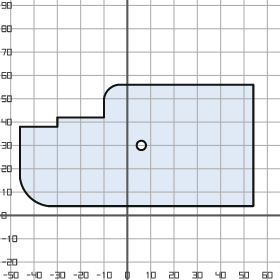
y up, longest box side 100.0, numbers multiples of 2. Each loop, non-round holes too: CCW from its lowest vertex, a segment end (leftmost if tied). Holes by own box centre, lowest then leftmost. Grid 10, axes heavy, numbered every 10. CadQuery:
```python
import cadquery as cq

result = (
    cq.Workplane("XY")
    .moveTo(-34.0, 4.0)
    .lineTo(54.0, 4.0)
    .lineTo(54.0, 56.0)
    .lineTo(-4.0, 56.0)
    .threePointArc((-8.0, 54.0), (-10.0, 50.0))
    .lineTo(-10.0, 42.0)
    .lineTo(-30.0, 42.0)
    .lineTo(-30.0, 38.0)
    .lineTo(-46.0, 38.0)
    .lineTo(-46.0, 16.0)
    .threePointArc((-42.0, 8.0), (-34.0, 4.0))
    .close()
    .moveTo(6.0, 30.0)
    .circle(2.0)
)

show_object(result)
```